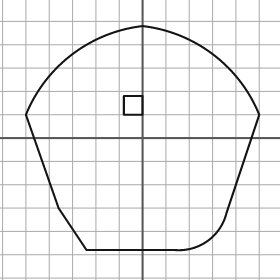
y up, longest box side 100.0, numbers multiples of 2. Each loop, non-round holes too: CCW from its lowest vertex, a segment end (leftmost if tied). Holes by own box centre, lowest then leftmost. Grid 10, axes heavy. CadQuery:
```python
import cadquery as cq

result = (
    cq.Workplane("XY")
    .moveTo(-24.0, -48.0)
    .lineTo(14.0, -48.0)
    .threePointArc((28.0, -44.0), (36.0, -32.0))
    .lineTo(50.0, 10.0)
    .threePointArc((30.0, 36.0), (0.0, 48.0))
    .threePointArc((-30.0, 36.0), (-50.0, 10.0))
    .lineTo(-36.0, -30.0)
    .close()
    .moveTo(-8.0, 10.0)
    .lineTo(0.0, 10.0)
    .lineTo(0.0, 18.0)
    .lineTo(-8.0, 18.0)
    .close()
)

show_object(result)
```